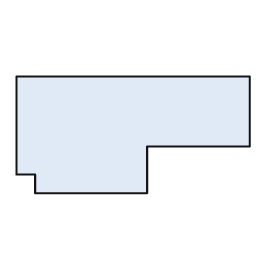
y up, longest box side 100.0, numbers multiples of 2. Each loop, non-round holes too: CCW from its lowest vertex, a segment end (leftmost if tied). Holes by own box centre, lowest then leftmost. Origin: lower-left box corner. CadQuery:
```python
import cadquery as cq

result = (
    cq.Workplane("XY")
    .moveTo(8.0, 0.0)
    .lineTo(56.0, 0.0)
    .lineTo(56.0, 20.0)
    .lineTo(100.0, 20.0)
    .lineTo(100.0, 50.0)
    .lineTo(0.0, 50.0)
    .lineTo(0.0, 8.0)
    .lineTo(8.0, 8.0)
    .close()
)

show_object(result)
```